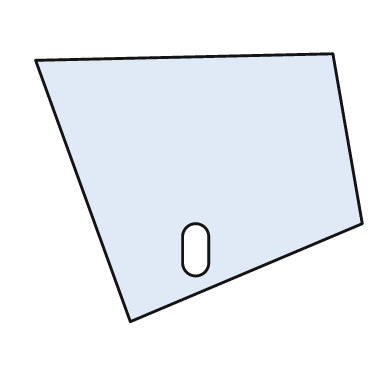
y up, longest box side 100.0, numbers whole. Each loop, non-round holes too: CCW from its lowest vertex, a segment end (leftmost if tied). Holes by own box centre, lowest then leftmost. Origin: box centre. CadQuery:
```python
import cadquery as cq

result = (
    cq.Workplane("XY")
    .moveTo(-21.0, -41.0)
    .lineTo(50.0, -11.0)
    .lineTo(41.0, 41.0)
    .lineTo(-50.0, 39.0)
    .close()
    .moveTo(-5.0, -23.0)
    .threePointArc((-1.0, -27.0), (3.0, -23.0))
    .lineTo(3.0, -15.0)
    .threePointArc((-1.0, -11.0), (-5.0, -15.0))
    .close()
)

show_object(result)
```